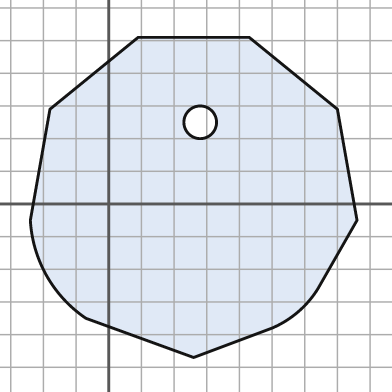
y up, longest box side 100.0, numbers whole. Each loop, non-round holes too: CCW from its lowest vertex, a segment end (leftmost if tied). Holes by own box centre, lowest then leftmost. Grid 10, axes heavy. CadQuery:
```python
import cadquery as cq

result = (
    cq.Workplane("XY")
    .moveTo(26.0, -47.0)
    .lineTo(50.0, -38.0)
    .threePointArc((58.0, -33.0), (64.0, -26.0))
    .lineTo(76.0, -5.0)
    .lineTo(70.0, 29.0)
    .lineTo(43.0, 51.0)
    .lineTo(9.0, 51.0)
    .lineTo(-18.0, 29.0)
    .lineTo(-24.0, -5.0)
    .threePointArc((-19.0, -22.0), (-7.0, -35.0))
    .close()
    .moveTo(28.0, 25.0)
    .circle(5.0)
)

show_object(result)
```